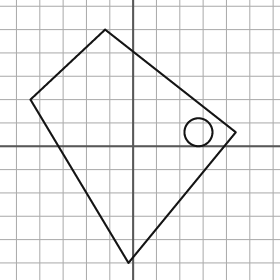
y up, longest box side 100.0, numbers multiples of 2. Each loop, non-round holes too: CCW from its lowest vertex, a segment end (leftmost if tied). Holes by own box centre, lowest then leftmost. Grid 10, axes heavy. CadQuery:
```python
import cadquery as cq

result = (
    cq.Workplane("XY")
    .moveTo(-2.0, -50.0)
    .lineTo(44.0, 6.0)
    .lineTo(-12.0, 50.0)
    .lineTo(-44.0, 20.0)
    .close()
    .moveTo(28.0, 6.0)
    .circle(6.0)
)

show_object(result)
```